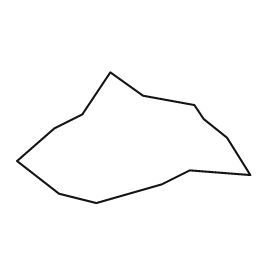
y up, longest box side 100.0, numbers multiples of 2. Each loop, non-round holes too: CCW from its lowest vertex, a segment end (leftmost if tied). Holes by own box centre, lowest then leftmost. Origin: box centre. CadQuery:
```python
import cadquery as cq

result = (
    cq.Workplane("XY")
    .moveTo(-16.0, -28.0)
    .lineTo(12.0, -20.0)
    .lineTo(24.0, -14.0)
    .lineTo(50.0, -16.0)
    .lineTo(40.0, 0.0)
    .lineTo(30.0, 8.0)
    .lineTo(26.0, 14.0)
    .lineTo(4.0, 18.0)
    .lineTo(-10.0, 28.0)
    .lineTo(-22.0, 10.0)
    .lineTo(-34.0, 4.0)
    .lineTo(-50.0, -10.0)
    .lineTo(-32.0, -24.0)
    .close()
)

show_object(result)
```